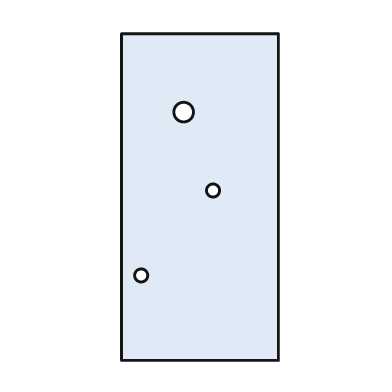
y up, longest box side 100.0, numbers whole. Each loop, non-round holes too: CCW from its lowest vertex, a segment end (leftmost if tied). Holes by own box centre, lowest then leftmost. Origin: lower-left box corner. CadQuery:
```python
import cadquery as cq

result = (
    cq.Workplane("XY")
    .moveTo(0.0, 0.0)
    .lineTo(48.0, 0.0)
    .lineTo(48.0, 100.0)
    .lineTo(0.0, 100.0)
    .close()
    .moveTo(6.0, 26.0)
    .circle(2.0)
    .moveTo(28.0, 52.0)
    .circle(2.0)
    .moveTo(19.0, 76.0)
    .circle(3.0)
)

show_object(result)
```